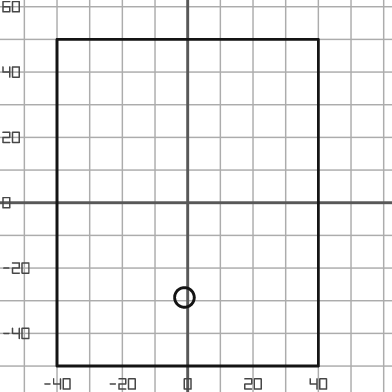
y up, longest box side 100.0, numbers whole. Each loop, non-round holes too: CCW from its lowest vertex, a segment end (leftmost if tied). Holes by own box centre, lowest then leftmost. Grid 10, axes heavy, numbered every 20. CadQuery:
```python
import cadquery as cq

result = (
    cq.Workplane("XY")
    .moveTo(-40.0, -50.0)
    .lineTo(40.0, -50.0)
    .lineTo(40.0, 50.0)
    .lineTo(-40.0, 50.0)
    .close()
    .moveTo(-1.0, -29.0)
    .circle(3.0)
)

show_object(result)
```